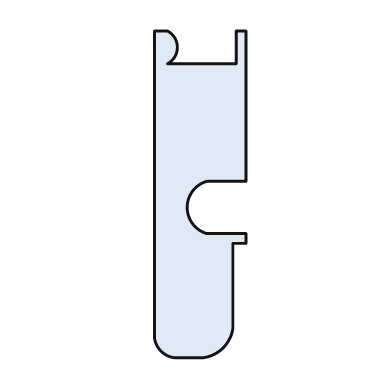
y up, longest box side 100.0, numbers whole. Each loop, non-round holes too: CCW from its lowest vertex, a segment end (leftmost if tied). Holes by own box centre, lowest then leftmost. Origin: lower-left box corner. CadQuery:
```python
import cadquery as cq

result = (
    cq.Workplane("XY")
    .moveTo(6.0, 0.0)
    .lineTo(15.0, 0.0)
    .threePointArc((21.0, 3.0), (24.0, 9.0))
    .lineTo(24.0, 35.0)
    .lineTo(28.0, 35.0)
    .lineTo(28.0, 38.0)
    .lineTo(16.0, 38.0)
    .threePointArc((10.0, 46.0), (16.0, 54.0))
    .lineTo(28.0, 54.0)
    .lineTo(28.0, 100.0)
    .lineTo(25.0, 100.0)
    .lineTo(25.0, 90.0)
    .lineTo(4.0, 90.0)
    .threePointArc((7.0, 95.0), (4.0, 100.0))
    .lineTo(0.0, 100.0)
    .lineTo(0.0, 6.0)
    .threePointArc((2.0, 2.0), (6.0, 0.0))
    .close()
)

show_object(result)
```